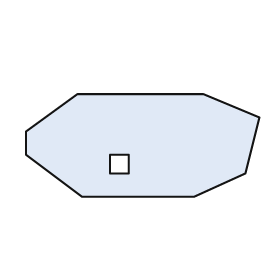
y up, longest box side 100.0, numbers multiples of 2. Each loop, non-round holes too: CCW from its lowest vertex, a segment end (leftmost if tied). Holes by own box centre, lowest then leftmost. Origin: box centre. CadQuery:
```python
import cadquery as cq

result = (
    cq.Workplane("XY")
    .moveTo(-26.0, -22.0)
    .lineTo(22.0, -22.0)
    .lineTo(44.0, -12.0)
    .lineTo(50.0, 12.0)
    .lineTo(26.0, 22.0)
    .lineTo(-28.0, 22.0)
    .lineTo(-50.0, 6.0)
    .lineTo(-50.0, -4.0)
    .close()
    .moveTo(-14.0, -12.0)
    .lineTo(-6.0, -12.0)
    .lineTo(-6.0, -4.0)
    .lineTo(-14.0, -4.0)
    .close()
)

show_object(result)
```